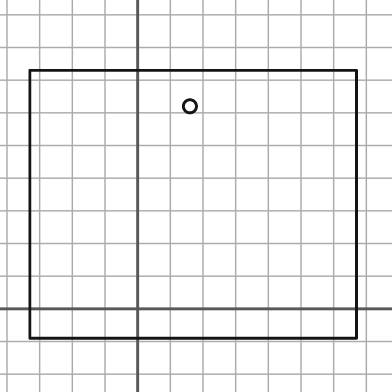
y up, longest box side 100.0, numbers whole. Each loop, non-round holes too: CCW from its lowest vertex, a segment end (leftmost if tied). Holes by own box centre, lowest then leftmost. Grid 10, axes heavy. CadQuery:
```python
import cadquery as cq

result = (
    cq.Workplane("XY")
    .moveTo(-33.0, -9.0)
    .lineTo(67.0, -9.0)
    .lineTo(67.0, 73.0)
    .lineTo(-33.0, 73.0)
    .close()
    .moveTo(16.0, 62.0)
    .circle(2.0)
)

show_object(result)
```